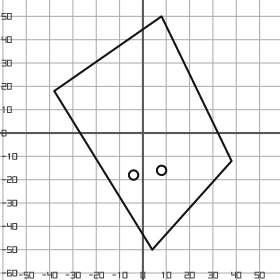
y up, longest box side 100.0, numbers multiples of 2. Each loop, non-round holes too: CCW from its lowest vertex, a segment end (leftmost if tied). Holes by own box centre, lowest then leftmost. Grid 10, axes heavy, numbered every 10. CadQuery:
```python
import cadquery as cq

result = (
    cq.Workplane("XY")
    .moveTo(4.0, -50.0)
    .lineTo(38.0, -12.0)
    .lineTo(8.0, 50.0)
    .lineTo(-38.0, 18.0)
    .close()
    .moveTo(-4.0, -18.0)
    .circle(2.0)
    .moveTo(8.0, -16.0)
    .circle(2.0)
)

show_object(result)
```